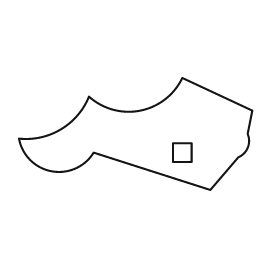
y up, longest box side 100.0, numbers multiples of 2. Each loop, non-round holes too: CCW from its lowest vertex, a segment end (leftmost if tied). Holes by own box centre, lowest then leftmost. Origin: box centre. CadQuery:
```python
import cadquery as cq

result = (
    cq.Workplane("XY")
    .moveTo(32.0, -24.0)
    .lineTo(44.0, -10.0)
    .threePointArc((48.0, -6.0), (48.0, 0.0))
    .lineTo(50.0, 10.0)
    .lineTo(20.0, 24.0)
    .threePointArc((2.0, 10.0), (-20.0, 16.0))
    .threePointArc((-32.0, 2.0), (-50.0, -2.0))
    .threePointArc((-36.0, -16.0), (-18.0, -8.0))
    .close()
    .moveTo(16.0, -12.0)
    .lineTo(24.0, -12.0)
    .lineTo(24.0, -4.0)
    .lineTo(16.0, -4.0)
    .close()
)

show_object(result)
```